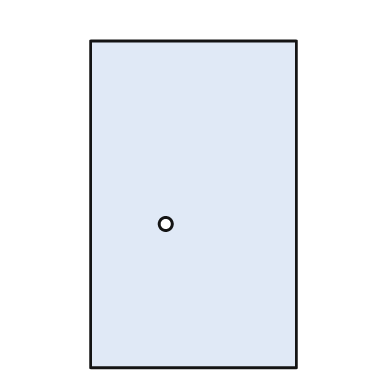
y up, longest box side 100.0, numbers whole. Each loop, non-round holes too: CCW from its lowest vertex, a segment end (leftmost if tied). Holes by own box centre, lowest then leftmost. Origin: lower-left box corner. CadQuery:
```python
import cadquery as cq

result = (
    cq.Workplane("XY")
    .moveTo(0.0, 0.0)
    .lineTo(63.0, 0.0)
    .lineTo(63.0, 100.0)
    .lineTo(0.0, 100.0)
    .close()
    .moveTo(23.0, 44.0)
    .circle(2.0)
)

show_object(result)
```